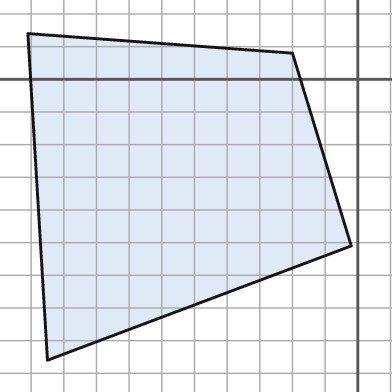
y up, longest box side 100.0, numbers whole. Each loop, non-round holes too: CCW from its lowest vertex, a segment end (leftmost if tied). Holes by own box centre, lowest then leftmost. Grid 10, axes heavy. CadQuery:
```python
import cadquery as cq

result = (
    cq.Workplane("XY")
    .moveTo(-95.0, -86.0)
    .lineTo(-2.0, -51.0)
    .lineTo(-20.0, 8.0)
    .lineTo(-101.0, 14.0)
    .close()
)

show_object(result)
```